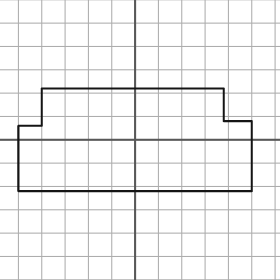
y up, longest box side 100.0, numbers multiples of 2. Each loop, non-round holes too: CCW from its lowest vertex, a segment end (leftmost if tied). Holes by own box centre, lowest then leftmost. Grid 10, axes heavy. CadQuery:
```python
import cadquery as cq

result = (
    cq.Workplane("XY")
    .moveTo(-50.0, -22.0)
    .lineTo(50.0, -22.0)
    .lineTo(50.0, 8.0)
    .lineTo(38.0, 8.0)
    .lineTo(38.0, 22.0)
    .lineTo(-40.0, 22.0)
    .lineTo(-40.0, 6.0)
    .lineTo(-50.0, 6.0)
    .close()
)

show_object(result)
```